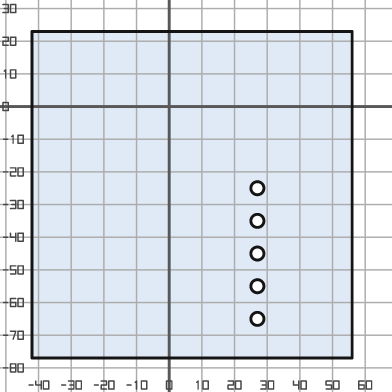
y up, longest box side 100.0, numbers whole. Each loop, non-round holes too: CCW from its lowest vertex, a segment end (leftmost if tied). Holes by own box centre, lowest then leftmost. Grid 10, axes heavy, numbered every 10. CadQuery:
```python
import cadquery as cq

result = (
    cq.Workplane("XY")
    .moveTo(-42.0, -77.0)
    .lineTo(56.0, -77.0)
    .lineTo(56.0, 23.0)
    .lineTo(-42.0, 23.0)
    .close()
    .moveTo(27.0, -65.0)
    .circle(2.0)
    .moveTo(27.0, -55.0)
    .circle(2.0)
    .moveTo(27.0, -45.0)
    .circle(2.0)
    .moveTo(27.0, -35.0)
    .circle(2.0)
    .moveTo(27.0, -25.0)
    .circle(2.0)
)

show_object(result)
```